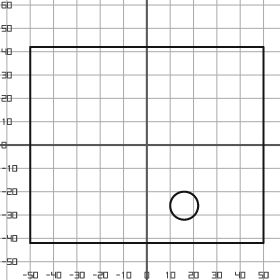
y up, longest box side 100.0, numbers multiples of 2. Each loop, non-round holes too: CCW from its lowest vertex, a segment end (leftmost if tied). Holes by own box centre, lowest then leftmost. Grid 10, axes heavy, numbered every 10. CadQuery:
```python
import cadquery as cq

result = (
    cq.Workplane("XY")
    .moveTo(-50.0, -42.0)
    .lineTo(50.0, -42.0)
    .lineTo(50.0, 42.0)
    .lineTo(-50.0, 42.0)
    .close()
    .moveTo(16.0, -26.0)
    .circle(6.0)
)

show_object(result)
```